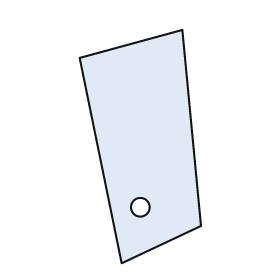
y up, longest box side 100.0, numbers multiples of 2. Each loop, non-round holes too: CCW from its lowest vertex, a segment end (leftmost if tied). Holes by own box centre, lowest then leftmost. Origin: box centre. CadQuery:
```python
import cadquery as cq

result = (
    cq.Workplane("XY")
    .moveTo(-8.0, -50.0)
    .lineTo(26.0, -34.0)
    .lineTo(18.0, 50.0)
    .lineTo(-26.0, 38.0)
    .close()
    .moveTo(0.0, -26.0)
    .circle(4.0)
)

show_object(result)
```